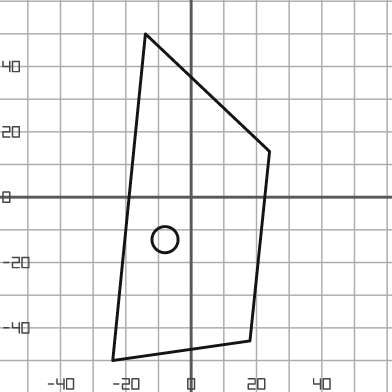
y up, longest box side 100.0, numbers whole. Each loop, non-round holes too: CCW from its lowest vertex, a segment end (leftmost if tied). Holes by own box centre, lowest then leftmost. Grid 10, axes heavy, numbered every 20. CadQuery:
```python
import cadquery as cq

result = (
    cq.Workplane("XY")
    .moveTo(-24.0, -50.0)
    .lineTo(18.0, -44.0)
    .lineTo(24.0, 14.0)
    .lineTo(-14.0, 50.0)
    .close()
    .moveTo(-8.0, -13.0)
    .circle(4.0)
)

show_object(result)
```